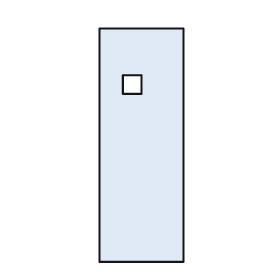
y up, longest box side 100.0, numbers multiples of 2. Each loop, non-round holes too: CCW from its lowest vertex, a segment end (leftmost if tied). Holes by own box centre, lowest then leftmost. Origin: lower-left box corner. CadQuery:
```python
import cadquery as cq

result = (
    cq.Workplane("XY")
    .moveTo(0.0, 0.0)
    .lineTo(36.0, 0.0)
    .lineTo(36.0, 100.0)
    .lineTo(0.0, 100.0)
    .close()
    .moveTo(10.0, 72.0)
    .lineTo(18.0, 72.0)
    .lineTo(18.0, 80.0)
    .lineTo(10.0, 80.0)
    .close()
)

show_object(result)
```